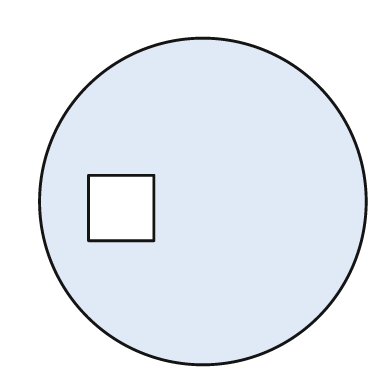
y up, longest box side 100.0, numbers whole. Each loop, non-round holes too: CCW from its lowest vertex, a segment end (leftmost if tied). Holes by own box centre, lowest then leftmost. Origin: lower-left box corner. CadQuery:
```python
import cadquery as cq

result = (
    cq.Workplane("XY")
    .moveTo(50.0, 50.0)
    .circle(50.0)
    .moveTo(15.0, 38.0)
    .lineTo(35.0, 38.0)
    .lineTo(35.0, 58.0)
    .lineTo(15.0, 58.0)
    .close()
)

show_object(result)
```